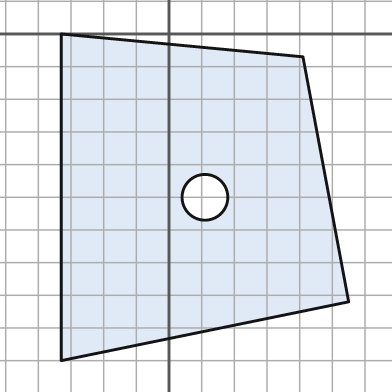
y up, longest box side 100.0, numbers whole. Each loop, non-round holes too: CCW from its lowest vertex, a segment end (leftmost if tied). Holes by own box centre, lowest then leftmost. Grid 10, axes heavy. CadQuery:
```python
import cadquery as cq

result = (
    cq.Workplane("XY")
    .moveTo(-33.0, -100.0)
    .lineTo(55.0, -82.0)
    .lineTo(41.0, -7.0)
    .lineTo(-33.0, 0.0)
    .close()
    .moveTo(11.0, -50.0)
    .circle(7.0)
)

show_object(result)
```